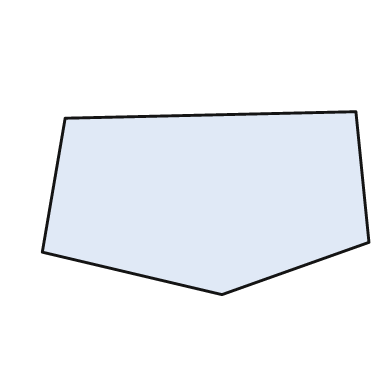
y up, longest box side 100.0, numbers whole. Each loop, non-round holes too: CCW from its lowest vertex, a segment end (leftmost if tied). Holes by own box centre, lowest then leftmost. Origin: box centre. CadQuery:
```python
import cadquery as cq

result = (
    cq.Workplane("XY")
    .moveTo(5.0, -28.0)
    .lineTo(50.0, -12.0)
    .lineTo(46.0, 28.0)
    .lineTo(-43.0, 26.0)
    .lineTo(-50.0, -15.0)
    .close()
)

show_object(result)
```